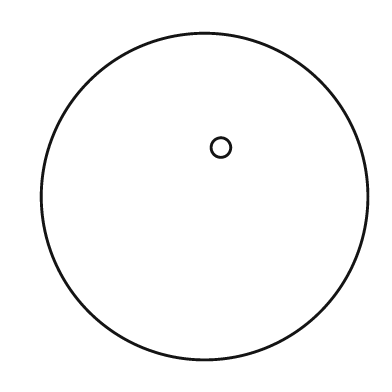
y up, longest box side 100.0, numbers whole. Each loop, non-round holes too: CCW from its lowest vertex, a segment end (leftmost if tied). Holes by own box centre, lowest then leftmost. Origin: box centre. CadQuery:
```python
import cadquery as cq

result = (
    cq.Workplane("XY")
    .moveTo(0.0, 0.0)
    .circle(50.0)
    .moveTo(5.0, 15.0)
    .circle(3.0)
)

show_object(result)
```